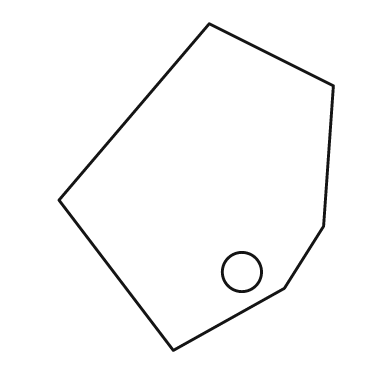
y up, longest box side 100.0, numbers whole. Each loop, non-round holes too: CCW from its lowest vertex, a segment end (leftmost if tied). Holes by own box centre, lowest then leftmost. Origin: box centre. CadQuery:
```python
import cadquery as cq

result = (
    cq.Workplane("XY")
    .moveTo(-7.0, -50.0)
    .lineTo(27.0, -31.0)
    .lineTo(39.0, -12.0)
    .lineTo(42.0, 31.0)
    .lineTo(4.0, 50.0)
    .lineTo(-42.0, -4.0)
    .close()
    .moveTo(14.0, -26.0)
    .circle(6.0)
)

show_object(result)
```